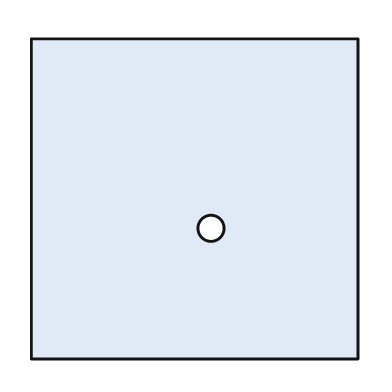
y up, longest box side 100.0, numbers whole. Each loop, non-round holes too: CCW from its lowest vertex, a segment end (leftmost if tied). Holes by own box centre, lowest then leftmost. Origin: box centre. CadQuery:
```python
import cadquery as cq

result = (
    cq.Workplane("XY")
    .moveTo(-50.0, -49.0)
    .lineTo(50.0, -49.0)
    .lineTo(50.0, 49.0)
    .lineTo(-50.0, 49.0)
    .close()
    .moveTo(5.0, -9.0)
    .circle(4.0)
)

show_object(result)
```